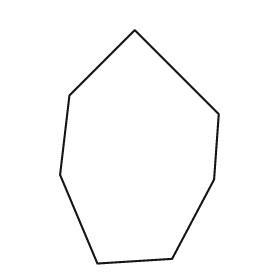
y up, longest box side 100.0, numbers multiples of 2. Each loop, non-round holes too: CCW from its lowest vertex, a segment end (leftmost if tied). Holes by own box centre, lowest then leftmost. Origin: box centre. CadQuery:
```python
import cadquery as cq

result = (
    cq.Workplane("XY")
    .moveTo(-18.0, -50.0)
    .lineTo(14.0, -48.0)
    .lineTo(32.0, -14.0)
    .lineTo(34.0, 14.0)
    .lineTo(-2.0, 50.0)
    .lineTo(-30.0, 22.0)
    .lineTo(-34.0, -12.0)
    .close()
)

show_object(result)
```